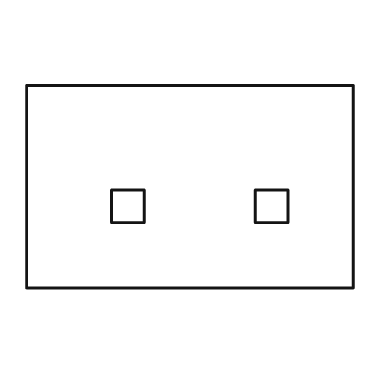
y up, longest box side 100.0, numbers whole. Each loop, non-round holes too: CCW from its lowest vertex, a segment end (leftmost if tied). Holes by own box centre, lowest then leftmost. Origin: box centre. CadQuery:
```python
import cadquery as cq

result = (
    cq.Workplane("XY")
    .moveTo(-50.0, -31.0)
    .lineTo(50.0, -31.0)
    .lineTo(50.0, 31.0)
    .lineTo(-50.0, 31.0)
    .close()
    .moveTo(-24.0, -11.0)
    .lineTo(-14.0, -11.0)
    .lineTo(-14.0, -1.0)
    .lineTo(-24.0, -1.0)
    .close()
    .moveTo(20.0, -11.0)
    .lineTo(30.0, -11.0)
    .lineTo(30.0, -1.0)
    .lineTo(20.0, -1.0)
    .close()
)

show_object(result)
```